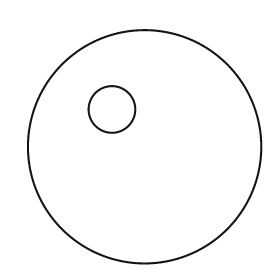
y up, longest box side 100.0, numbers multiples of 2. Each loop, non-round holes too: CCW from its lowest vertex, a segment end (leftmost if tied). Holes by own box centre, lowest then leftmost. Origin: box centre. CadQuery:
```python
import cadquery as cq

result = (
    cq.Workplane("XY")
    .moveTo(0.0, 0.0)
    .circle(50.0)
    .moveTo(-14.0, 16.0)
    .circle(10.0)
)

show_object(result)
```